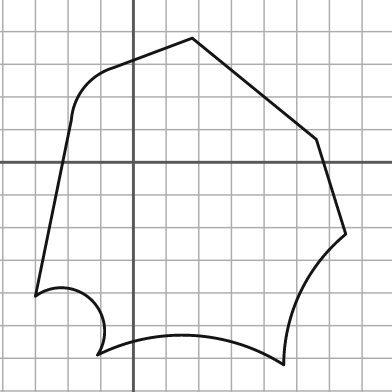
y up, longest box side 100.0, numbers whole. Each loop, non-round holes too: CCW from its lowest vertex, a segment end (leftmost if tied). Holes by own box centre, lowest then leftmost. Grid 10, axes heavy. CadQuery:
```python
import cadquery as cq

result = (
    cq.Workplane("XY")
    .moveTo(46.0, -62.0)
    .threePointArc((51.0, -40.0), (65.0, -22.0))
    .lineTo(56.0, 7.0)
    .lineTo(18.0, 38.0)
    .lineTo(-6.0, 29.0)
    .threePointArc((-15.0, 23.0), (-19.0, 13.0))
    .lineTo(-30.0, -41.0)
    .threePointArc((-13.0, -42.0), (-11.0, -59.0))
    .threePointArc((18.0, -53.0), (46.0, -62.0))
    .close()
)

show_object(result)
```